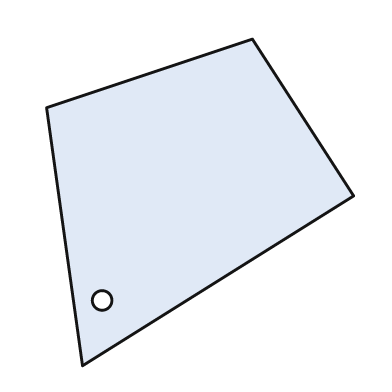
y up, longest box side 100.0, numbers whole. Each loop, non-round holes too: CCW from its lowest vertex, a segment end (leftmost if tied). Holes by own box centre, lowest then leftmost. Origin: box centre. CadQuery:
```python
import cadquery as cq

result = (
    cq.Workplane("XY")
    .moveTo(-36.0, -50.0)
    .lineTo(47.0, 2.0)
    .lineTo(16.0, 50.0)
    .lineTo(-47.0, 29.0)
    .close()
    .moveTo(-30.0, -30.0)
    .circle(3.0)
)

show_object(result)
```